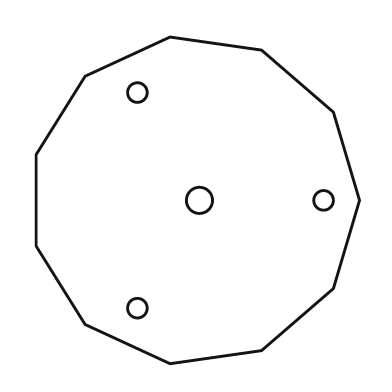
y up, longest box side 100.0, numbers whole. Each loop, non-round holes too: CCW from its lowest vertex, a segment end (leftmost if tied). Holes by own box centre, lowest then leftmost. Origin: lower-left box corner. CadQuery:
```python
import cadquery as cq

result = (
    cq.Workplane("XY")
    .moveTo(41.0, 0.0)
    .lineTo(69.0, 4.0)
    .lineTo(91.0, 23.0)
    .lineTo(99.0, 50.0)
    .lineTo(91.0, 77.0)
    .lineTo(69.0, 96.0)
    .lineTo(41.0, 100.0)
    .lineTo(15.0, 88.0)
    .lineTo(0.0, 64.0)
    .lineTo(0.0, 36.0)
    .lineTo(15.0, 12.0)
    .close()
    .moveTo(31.0, 17.0)
    .circle(3.0)
    .moveTo(50.0, 50.0)
    .circle(4.0)
    .moveTo(88.0, 50.0)
    .circle(3.0)
    .moveTo(31.0, 83.0)
    .circle(3.0)
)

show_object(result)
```